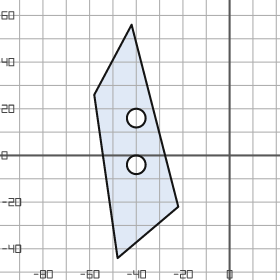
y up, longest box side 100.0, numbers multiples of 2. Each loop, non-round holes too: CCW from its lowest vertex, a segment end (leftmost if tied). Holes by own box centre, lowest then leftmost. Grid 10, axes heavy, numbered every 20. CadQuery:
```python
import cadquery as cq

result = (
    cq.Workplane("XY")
    .moveTo(-48.0, -44.0)
    .lineTo(-22.0, -22.0)
    .lineTo(-42.0, 56.0)
    .lineTo(-58.0, 26.0)
    .close()
    .moveTo(-40.0, -4.0)
    .circle(4.0)
    .moveTo(-40.0, 16.0)
    .circle(4.0)
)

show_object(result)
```